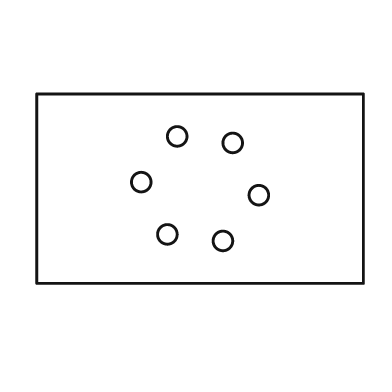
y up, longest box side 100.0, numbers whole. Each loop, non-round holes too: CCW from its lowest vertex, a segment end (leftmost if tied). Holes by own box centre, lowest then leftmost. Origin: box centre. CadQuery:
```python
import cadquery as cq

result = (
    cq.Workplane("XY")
    .moveTo(-50.0, -29.0)
    .lineTo(50.0, -29.0)
    .lineTo(50.0, 29.0)
    .lineTo(-50.0, 29.0)
    .close()
    .moveTo(7.0, -16.0)
    .circle(3.0)
    .moveTo(-10.0, -14.0)
    .circle(3.0)
    .moveTo(18.0, -2.0)
    .circle(3.0)
    .moveTo(-18.0, 2.0)
    .circle(3.0)
    .moveTo(10.0, 14.0)
    .circle(3.0)
    .moveTo(-7.0, 16.0)
    .circle(3.0)
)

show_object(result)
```